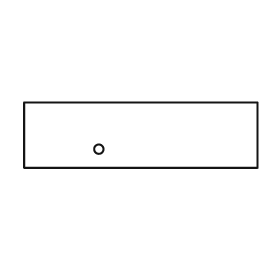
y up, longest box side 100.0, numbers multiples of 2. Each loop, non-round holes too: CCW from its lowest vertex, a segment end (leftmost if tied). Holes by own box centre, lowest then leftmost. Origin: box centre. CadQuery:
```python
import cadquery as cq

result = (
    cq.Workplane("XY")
    .moveTo(-50.0, -14.0)
    .lineTo(50.0, -14.0)
    .lineTo(50.0, 14.0)
    .lineTo(-50.0, 14.0)
    .close()
    .moveTo(-18.0, -6.0)
    .circle(2.0)
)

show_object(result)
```